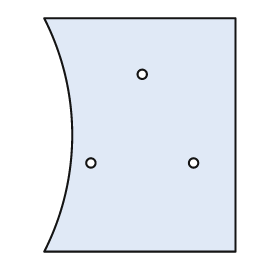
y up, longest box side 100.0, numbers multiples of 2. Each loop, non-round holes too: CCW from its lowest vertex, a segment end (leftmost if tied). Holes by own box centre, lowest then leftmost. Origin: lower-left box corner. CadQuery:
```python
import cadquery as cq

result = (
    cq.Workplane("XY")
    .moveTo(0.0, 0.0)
    .lineTo(82.0, 0.0)
    .lineTo(82.0, 100.0)
    .lineTo(0.0, 100.0)
    .threePointArc((12.0, 50.0), (0.0, 0.0))
    .close()
    .moveTo(20.0, 38.0)
    .circle(2.0)
    .moveTo(64.0, 38.0)
    .circle(2.0)
    .moveTo(42.0, 76.0)
    .circle(2.0)
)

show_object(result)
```